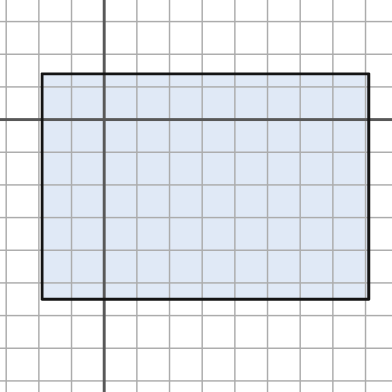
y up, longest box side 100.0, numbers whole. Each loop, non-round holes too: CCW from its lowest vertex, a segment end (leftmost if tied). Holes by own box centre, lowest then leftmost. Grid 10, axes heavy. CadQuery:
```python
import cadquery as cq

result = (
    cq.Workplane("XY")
    .moveTo(-19.0, -55.0)
    .lineTo(81.0, -55.0)
    .lineTo(81.0, 14.0)
    .lineTo(-19.0, 14.0)
    .close()
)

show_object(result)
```